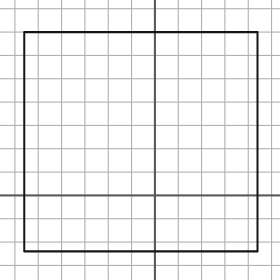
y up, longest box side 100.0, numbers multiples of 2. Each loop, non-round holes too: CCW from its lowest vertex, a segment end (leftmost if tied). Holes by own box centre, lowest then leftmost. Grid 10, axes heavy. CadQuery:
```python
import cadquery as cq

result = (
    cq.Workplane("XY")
    .moveTo(-56.0, -24.0)
    .lineTo(44.0, -24.0)
    .lineTo(44.0, 70.0)
    .lineTo(-56.0, 70.0)
    .close()
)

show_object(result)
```